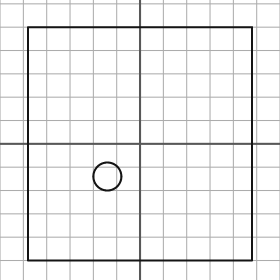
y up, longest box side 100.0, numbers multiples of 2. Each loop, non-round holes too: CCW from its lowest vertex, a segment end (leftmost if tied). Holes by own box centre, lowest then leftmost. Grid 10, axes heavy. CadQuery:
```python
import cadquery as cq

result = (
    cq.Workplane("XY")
    .moveTo(-48.0, -50.0)
    .lineTo(48.0, -50.0)
    .lineTo(48.0, 50.0)
    .lineTo(-48.0, 50.0)
    .close()
    .moveTo(-14.0, -14.0)
    .circle(6.0)
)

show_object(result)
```